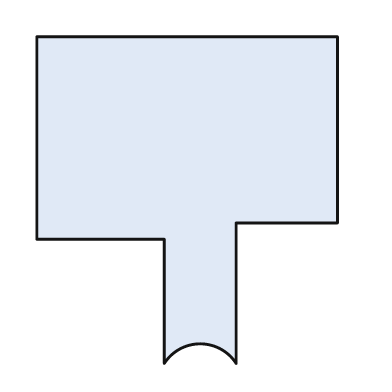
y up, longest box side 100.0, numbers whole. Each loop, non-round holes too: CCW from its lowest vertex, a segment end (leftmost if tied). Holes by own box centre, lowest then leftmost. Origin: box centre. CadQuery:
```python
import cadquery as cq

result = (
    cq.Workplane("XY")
    .moveTo(-7.0, -50.0)
    .threePointArc((4.0, -44.0), (15.0, -50.0))
    .lineTo(15.0, -7.0)
    .lineTo(46.0, -7.0)
    .lineTo(46.0, 50.0)
    .lineTo(-46.0, 50.0)
    .lineTo(-46.0, -12.0)
    .lineTo(-7.0, -12.0)
    .close()
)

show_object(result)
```